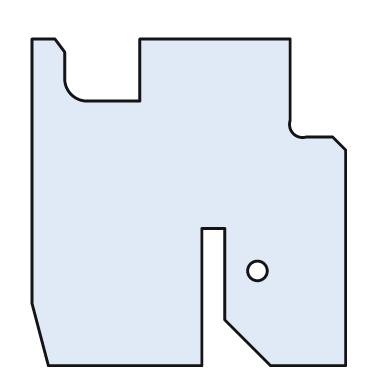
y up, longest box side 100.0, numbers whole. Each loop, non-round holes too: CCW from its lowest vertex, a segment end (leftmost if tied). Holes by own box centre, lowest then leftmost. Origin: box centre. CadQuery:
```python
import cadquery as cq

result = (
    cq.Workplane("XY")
    .moveTo(-43.0, -50.0)
    .lineTo(4.0, -50.0)
    .lineTo(4.0, -8.0)
    .lineTo(11.0, -8.0)
    .lineTo(11.0, -36.0)
    .lineTo(25.0, -50.0)
    .lineTo(48.0, -50.0)
    .lineTo(48.0, 16.0)
    .lineTo(44.0, 20.0)
    .lineTo(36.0, 20.0)
    .threePointArc((32.0, 21.0), (31.0, 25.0))
    .lineTo(31.0, 50.0)
    .lineTo(-15.0, 50.0)
    .lineTo(-15.0, 31.0)
    .lineTo(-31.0, 31.0)
    .threePointArc((-36.0, 33.0), (-38.0, 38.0))
    .lineTo(-38.0, 46.0)
    .lineTo(-41.0, 50.0)
    .lineTo(-48.0, 50.0)
    .lineTo(-48.0, -31.0)
    .close()
    .moveTo(21.0, -21.0)
    .circle(3.0)
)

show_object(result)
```